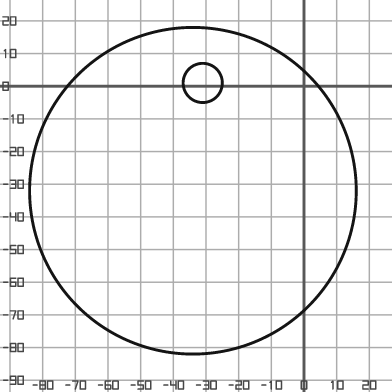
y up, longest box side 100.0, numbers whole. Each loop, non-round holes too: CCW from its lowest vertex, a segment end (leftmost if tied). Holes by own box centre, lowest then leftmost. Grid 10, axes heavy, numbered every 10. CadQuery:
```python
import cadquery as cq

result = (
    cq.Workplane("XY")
    .moveTo(-34.0, -32.0)
    .circle(50.0)
    .moveTo(-31.0, 1.0)
    .circle(6.0)
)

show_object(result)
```